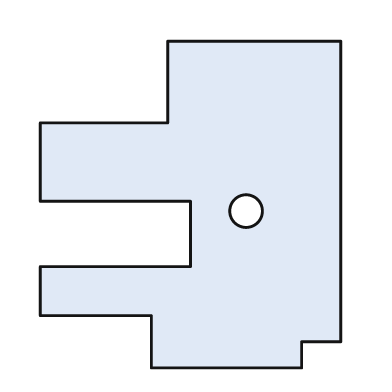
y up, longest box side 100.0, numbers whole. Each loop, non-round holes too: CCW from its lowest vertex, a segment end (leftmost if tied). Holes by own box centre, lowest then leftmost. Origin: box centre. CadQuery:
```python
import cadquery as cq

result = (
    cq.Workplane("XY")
    .moveTo(-12.0, -50.0)
    .lineTo(34.0, -50.0)
    .lineTo(34.0, -42.0)
    .lineTo(46.0, -42.0)
    .lineTo(46.0, 50.0)
    .lineTo(-7.0, 50.0)
    .lineTo(-7.0, 25.0)
    .lineTo(-46.0, 25.0)
    .lineTo(-46.0, 1.0)
    .lineTo(0.0, 1.0)
    .lineTo(0.0, -19.0)
    .lineTo(-46.0, -19.0)
    .lineTo(-46.0, -34.0)
    .lineTo(-12.0, -34.0)
    .close()
    .moveTo(17.0, -2.0)
    .circle(5.0)
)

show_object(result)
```